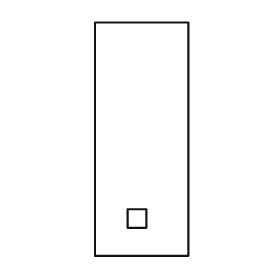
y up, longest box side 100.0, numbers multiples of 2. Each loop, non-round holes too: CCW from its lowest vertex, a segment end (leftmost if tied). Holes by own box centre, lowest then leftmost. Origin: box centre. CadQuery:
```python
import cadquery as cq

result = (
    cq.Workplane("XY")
    .moveTo(-20.0, -50.0)
    .lineTo(20.0, -50.0)
    .lineTo(20.0, 50.0)
    .lineTo(-20.0, 50.0)
    .close()
    .moveTo(-6.0, -38.0)
    .lineTo(2.0, -38.0)
    .lineTo(2.0, -30.0)
    .lineTo(-6.0, -30.0)
    .close()
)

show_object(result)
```